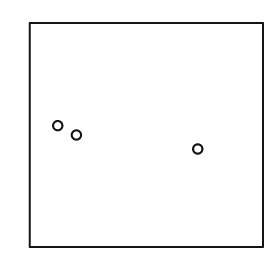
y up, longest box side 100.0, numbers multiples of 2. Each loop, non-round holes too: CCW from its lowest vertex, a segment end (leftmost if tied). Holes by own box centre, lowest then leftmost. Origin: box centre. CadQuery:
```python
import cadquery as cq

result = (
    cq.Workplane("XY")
    .moveTo(-50.0, -48.0)
    .lineTo(50.0, -48.0)
    .lineTo(50.0, 48.0)
    .lineTo(-50.0, 48.0)
    .close()
    .moveTo(22.0, -6.0)
    .circle(2.0)
    .moveTo(-30.0, 0.0)
    .circle(2.0)
    .moveTo(-38.0, 4.0)
    .circle(2.0)
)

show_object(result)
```